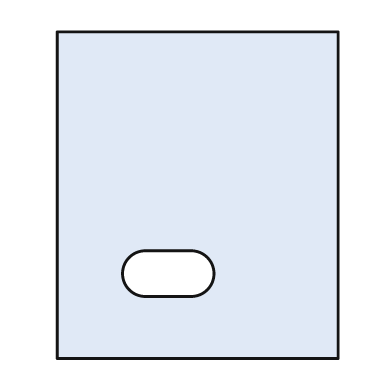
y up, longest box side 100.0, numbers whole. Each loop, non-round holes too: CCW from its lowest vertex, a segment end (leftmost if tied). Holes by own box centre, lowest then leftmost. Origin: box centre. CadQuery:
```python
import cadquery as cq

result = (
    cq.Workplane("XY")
    .moveTo(-43.0, -50.0)
    .lineTo(43.0, -50.0)
    .lineTo(43.0, 50.0)
    .lineTo(-43.0, 50.0)
    .close()
    .moveTo(-16.0, -31.0)
    .lineTo(-2.0, -31.0)
    .threePointArc((5.0, -24.0), (-2.0, -17.0))
    .lineTo(-16.0, -17.0)
    .threePointArc((-23.0, -24.0), (-16.0, -31.0))
    .close()
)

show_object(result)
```